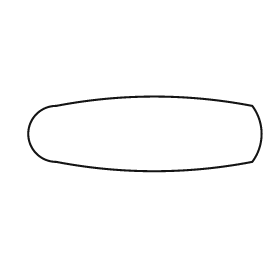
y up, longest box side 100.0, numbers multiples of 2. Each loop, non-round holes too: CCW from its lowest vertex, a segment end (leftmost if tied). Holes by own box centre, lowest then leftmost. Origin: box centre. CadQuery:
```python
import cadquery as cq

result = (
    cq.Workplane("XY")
    .moveTo(-38.0, -12.0)
    .threePointArc((4.0, -16.0), (46.0, -12.0))
    .threePointArc((50.0, 0.0), (46.0, 12.0))
    .threePointArc((4.0, 16.0), (-38.0, 12.0))
    .threePointArc((-50.0, 0.0), (-38.0, -12.0))
    .close()
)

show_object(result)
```